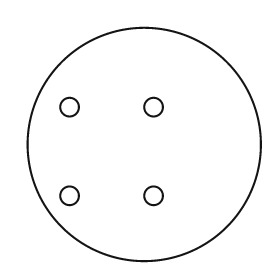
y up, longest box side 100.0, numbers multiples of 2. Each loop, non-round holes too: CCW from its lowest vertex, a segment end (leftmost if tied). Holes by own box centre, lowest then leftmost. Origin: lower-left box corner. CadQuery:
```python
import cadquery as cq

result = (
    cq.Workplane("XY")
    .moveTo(50.0, 50.0)
    .circle(50.0)
    .moveTo(18.0, 28.0)
    .circle(4.0)
    .moveTo(54.0, 28.0)
    .circle(4.0)
    .moveTo(18.0, 66.0)
    .circle(4.0)
    .moveTo(54.0, 66.0)
    .circle(4.0)
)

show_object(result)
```